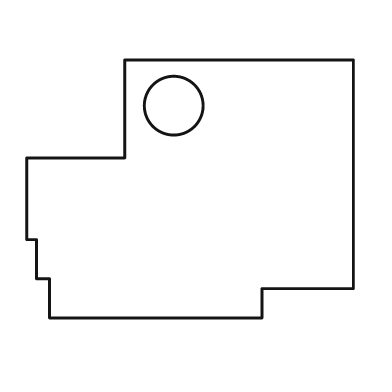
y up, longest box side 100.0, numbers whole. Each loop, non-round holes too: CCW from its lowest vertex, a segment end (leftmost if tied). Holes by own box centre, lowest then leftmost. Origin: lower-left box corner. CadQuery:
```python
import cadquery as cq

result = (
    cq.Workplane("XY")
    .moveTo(7.0, 0.0)
    .lineTo(72.0, 0.0)
    .lineTo(72.0, 9.0)
    .lineTo(100.0, 9.0)
    .lineTo(100.0, 79.0)
    .lineTo(30.0, 79.0)
    .lineTo(30.0, 49.0)
    .lineTo(0.0, 49.0)
    .lineTo(0.0, 24.0)
    .lineTo(3.0, 24.0)
    .lineTo(3.0, 12.0)
    .lineTo(7.0, 12.0)
    .close()
    .moveTo(45.0, 65.0)
    .circle(9.0)
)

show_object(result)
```